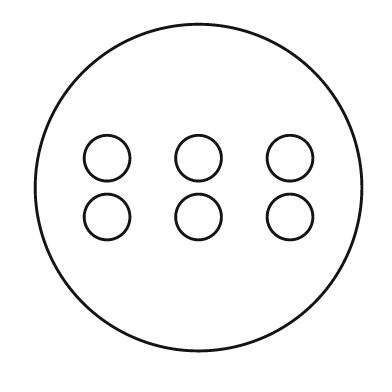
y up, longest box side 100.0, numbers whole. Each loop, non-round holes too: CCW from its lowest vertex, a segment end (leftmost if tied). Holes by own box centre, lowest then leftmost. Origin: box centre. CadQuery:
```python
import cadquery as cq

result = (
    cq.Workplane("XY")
    .moveTo(0.0, 0.0)
    .circle(50.0)
    .moveTo(-28.0, -9.0)
    .circle(7.0)
    .moveTo(0.0, -9.0)
    .circle(7.0)
    .moveTo(28.0, -9.0)
    .circle(7.0)
    .moveTo(-28.0, 9.0)
    .circle(7.0)
    .moveTo(0.0, 9.0)
    .circle(7.0)
    .moveTo(28.0, 9.0)
    .circle(7.0)
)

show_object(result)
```